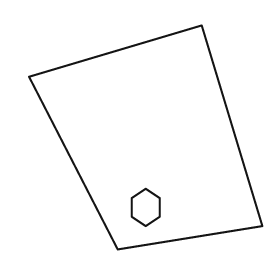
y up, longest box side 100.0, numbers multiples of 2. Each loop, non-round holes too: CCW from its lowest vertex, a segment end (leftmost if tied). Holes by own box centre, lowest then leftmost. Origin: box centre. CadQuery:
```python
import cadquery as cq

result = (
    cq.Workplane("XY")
    .moveTo(-12.0, -48.0)
    .lineTo(50.0, -38.0)
    .lineTo(24.0, 48.0)
    .lineTo(-50.0, 26.0)
    .close()
    .moveTo(0.0, -38.0)
    .lineTo(6.0, -34.0)
    .lineTo(6.0, -26.0)
    .lineTo(0.0, -22.0)
    .lineTo(-6.0, -26.0)
    .lineTo(-6.0, -34.0)
    .close()
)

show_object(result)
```